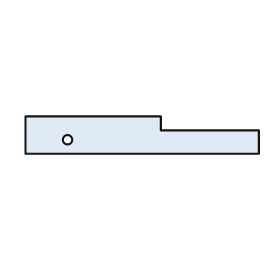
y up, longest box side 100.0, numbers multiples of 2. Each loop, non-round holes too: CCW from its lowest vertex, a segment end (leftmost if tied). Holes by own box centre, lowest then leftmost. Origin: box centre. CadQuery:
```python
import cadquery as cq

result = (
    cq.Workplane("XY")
    .moveTo(-50.0, -8.0)
    .lineTo(50.0, -8.0)
    .lineTo(50.0, 2.0)
    .lineTo(8.0, 2.0)
    .lineTo(8.0, 8.0)
    .lineTo(-50.0, 8.0)
    .close()
    .moveTo(-32.0, -2.0)
    .circle(2.0)
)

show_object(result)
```